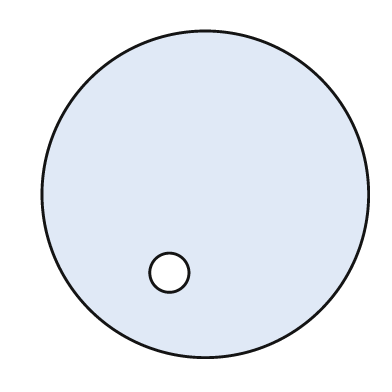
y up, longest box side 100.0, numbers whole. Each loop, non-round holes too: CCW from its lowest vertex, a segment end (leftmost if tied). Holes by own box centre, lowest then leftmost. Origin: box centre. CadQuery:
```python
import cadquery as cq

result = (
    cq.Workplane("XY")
    .moveTo(0.0, 0.0)
    .circle(50.0)
    .moveTo(-11.0, -24.0)
    .circle(6.0)
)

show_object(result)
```